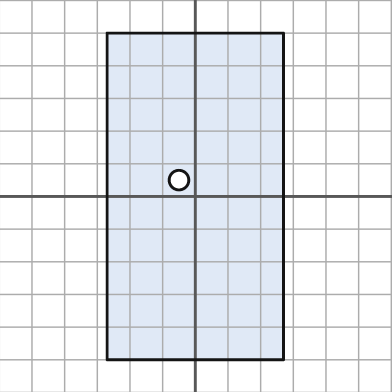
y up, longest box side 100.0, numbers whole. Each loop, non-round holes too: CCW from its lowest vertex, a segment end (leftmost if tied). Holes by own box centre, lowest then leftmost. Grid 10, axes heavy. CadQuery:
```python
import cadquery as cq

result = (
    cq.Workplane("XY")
    .moveTo(-27.0, -50.0)
    .lineTo(27.0, -50.0)
    .lineTo(27.0, 50.0)
    .lineTo(-27.0, 50.0)
    .close()
    .moveTo(-5.0, 5.0)
    .circle(3.0)
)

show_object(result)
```